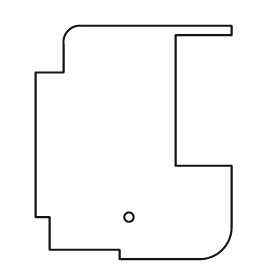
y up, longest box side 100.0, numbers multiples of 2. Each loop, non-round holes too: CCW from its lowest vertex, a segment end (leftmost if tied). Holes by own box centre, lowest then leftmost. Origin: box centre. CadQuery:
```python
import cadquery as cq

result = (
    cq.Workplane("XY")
    .moveTo(-6.0, -50.0)
    .lineTo(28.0, -50.0)
    .threePointArc((38.0, -46.0), (42.0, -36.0))
    .lineTo(42.0, -10.0)
    .lineTo(18.0, -10.0)
    .lineTo(18.0, 46.0)
    .lineTo(42.0, 46.0)
    .lineTo(42.0, 50.0)
    .lineTo(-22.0, 50.0)
    .threePointArc((-28.0, 48.0), (-30.0, 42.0))
    .lineTo(-30.0, 30.0)
    .lineTo(-42.0, 30.0)
    .lineTo(-42.0, -32.0)
    .lineTo(-36.0, -32.0)
    .lineTo(-36.0, -46.0)
    .lineTo(-6.0, -46.0)
    .close()
    .moveTo(-2.0, -32.0)
    .circle(2.0)
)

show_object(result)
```